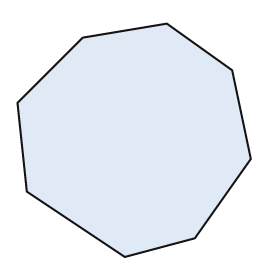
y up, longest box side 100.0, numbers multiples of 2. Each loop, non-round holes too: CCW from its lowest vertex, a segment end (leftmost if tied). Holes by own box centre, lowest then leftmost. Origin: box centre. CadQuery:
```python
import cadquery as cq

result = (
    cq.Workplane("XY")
    .moveTo(-4.0, -50.0)
    .lineTo(26.0, -42.0)
    .lineTo(50.0, -8.0)
    .lineTo(42.0, 30.0)
    .lineTo(14.0, 50.0)
    .lineTo(-22.0, 44.0)
    .lineTo(-50.0, 16.0)
    .lineTo(-46.0, -22.0)
    .close()
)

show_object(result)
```